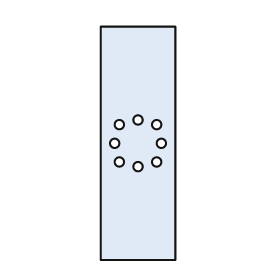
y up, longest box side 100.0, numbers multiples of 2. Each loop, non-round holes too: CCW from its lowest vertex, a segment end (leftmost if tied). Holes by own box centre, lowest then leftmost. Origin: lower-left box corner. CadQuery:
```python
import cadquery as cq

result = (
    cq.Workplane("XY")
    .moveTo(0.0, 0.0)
    .lineTo(32.0, 0.0)
    .lineTo(32.0, 100.0)
    .lineTo(0.0, 100.0)
    .close()
    .moveTo(16.0, 40.0)
    .circle(2.0)
    .moveTo(8.0, 42.0)
    .circle(2.0)
    .moveTo(24.0, 42.0)
    .circle(2.0)
    .moveTo(6.0, 50.0)
    .circle(2.0)
    .moveTo(26.0, 50.0)
    .circle(2.0)
    .moveTo(8.0, 58.0)
    .circle(2.0)
    .moveTo(24.0, 58.0)
    .circle(2.0)
    .moveTo(16.0, 60.0)
    .circle(2.0)
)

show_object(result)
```